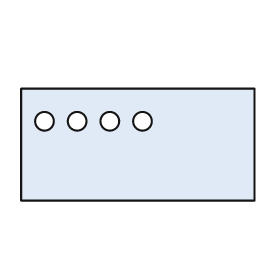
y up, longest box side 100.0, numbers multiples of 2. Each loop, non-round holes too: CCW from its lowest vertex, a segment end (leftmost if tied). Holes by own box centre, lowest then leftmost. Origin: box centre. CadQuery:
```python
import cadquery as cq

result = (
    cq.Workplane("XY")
    .moveTo(-50.0, -24.0)
    .lineTo(50.0, -24.0)
    .lineTo(50.0, 24.0)
    .lineTo(-50.0, 24.0)
    .close()
    .moveTo(-40.0, 10.0)
    .circle(4.0)
    .moveTo(-26.0, 10.0)
    .circle(4.0)
    .moveTo(-12.0, 10.0)
    .circle(4.0)
    .moveTo(2.0, 10.0)
    .circle(4.0)
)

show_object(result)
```